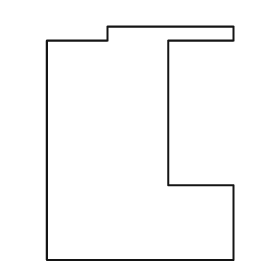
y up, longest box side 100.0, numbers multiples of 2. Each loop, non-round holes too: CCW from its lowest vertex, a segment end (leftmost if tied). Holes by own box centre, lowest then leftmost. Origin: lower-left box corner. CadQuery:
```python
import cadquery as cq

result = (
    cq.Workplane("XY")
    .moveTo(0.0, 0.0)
    .lineTo(80.0, 0.0)
    .lineTo(80.0, 32.0)
    .lineTo(52.0, 32.0)
    .lineTo(52.0, 94.0)
    .lineTo(80.0, 94.0)
    .lineTo(80.0, 100.0)
    .lineTo(26.0, 100.0)
    .lineTo(26.0, 94.0)
    .lineTo(0.0, 94.0)
    .close()
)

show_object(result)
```